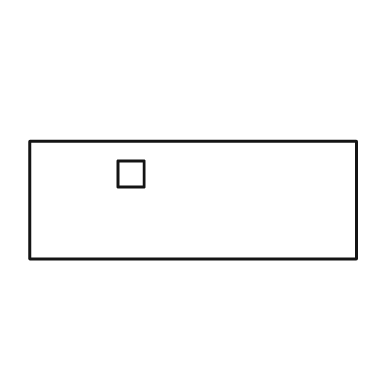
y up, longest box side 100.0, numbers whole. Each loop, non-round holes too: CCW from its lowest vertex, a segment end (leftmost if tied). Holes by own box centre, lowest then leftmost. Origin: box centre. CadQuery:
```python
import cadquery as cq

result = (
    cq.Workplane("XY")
    .moveTo(-50.0, -18.0)
    .lineTo(50.0, -18.0)
    .lineTo(50.0, 18.0)
    .lineTo(-50.0, 18.0)
    .close()
    .moveTo(-23.0, 4.0)
    .lineTo(-15.0, 4.0)
    .lineTo(-15.0, 12.0)
    .lineTo(-23.0, 12.0)
    .close()
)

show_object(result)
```